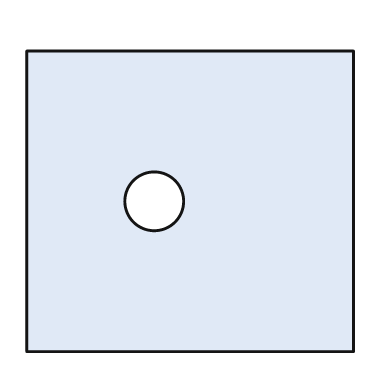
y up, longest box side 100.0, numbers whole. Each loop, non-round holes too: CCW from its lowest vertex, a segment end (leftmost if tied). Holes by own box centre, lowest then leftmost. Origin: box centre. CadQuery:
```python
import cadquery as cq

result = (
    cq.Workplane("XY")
    .moveTo(-50.0, -46.0)
    .lineTo(50.0, -46.0)
    .lineTo(50.0, 46.0)
    .lineTo(-50.0, 46.0)
    .close()
    .moveTo(-11.0, 0.0)
    .circle(9.0)
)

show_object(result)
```